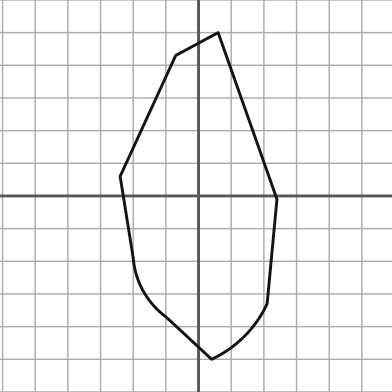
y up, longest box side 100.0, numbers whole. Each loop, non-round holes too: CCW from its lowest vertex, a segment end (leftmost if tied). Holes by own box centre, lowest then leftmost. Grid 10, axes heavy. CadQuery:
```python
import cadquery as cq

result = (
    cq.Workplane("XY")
    .moveTo(4.0, -50.0)
    .threePointArc((14.0, -43.0), (21.0, -33.0))
    .lineTo(24.0, -1.0)
    .lineTo(6.0, 50.0)
    .lineTo(-7.0, 43.0)
    .lineTo(-24.0, 6.0)
    .lineTo(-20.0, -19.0)
    .threePointArc((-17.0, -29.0), (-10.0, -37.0))
    .close()
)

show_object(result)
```